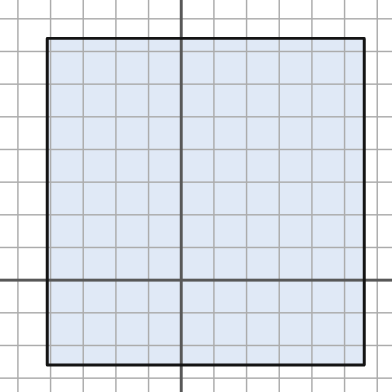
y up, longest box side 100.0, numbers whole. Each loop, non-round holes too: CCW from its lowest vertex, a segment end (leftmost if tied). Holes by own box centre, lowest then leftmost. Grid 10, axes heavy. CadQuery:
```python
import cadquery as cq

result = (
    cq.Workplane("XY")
    .moveTo(-41.0, -26.0)
    .lineTo(56.0, -26.0)
    .lineTo(56.0, 74.0)
    .lineTo(-41.0, 74.0)
    .close()
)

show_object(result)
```